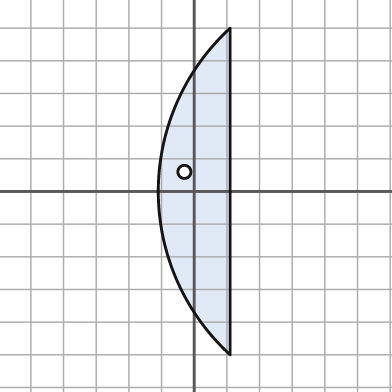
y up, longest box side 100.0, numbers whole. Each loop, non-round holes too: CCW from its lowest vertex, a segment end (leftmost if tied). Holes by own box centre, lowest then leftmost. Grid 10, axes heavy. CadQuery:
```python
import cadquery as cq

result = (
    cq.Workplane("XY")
    .moveTo(11.0, -50.0)
    .lineTo(11.0, 50.0)
    .threePointArc((-11.0, 0.0), (11.0, -50.0))
    .close()
    .moveTo(-3.0, 6.0)
    .circle(2.0)
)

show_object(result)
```